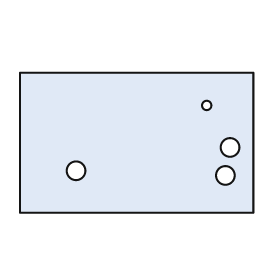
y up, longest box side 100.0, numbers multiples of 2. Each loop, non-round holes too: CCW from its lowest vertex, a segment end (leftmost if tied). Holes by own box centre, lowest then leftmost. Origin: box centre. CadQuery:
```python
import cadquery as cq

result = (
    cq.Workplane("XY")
    .moveTo(-50.0, -30.0)
    .lineTo(50.0, -30.0)
    .lineTo(50.0, 30.0)
    .lineTo(-50.0, 30.0)
    .close()
    .moveTo(38.0, -14.0)
    .circle(4.0)
    .moveTo(-26.0, -12.0)
    .circle(4.0)
    .moveTo(40.0, -2.0)
    .circle(4.0)
    .moveTo(30.0, 16.0)
    .circle(2.0)
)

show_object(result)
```